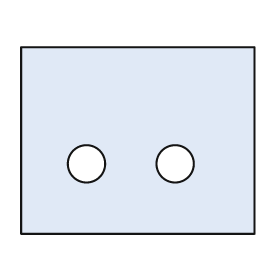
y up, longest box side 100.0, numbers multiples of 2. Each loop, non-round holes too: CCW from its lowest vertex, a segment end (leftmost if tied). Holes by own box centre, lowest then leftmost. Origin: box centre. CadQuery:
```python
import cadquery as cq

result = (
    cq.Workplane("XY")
    .moveTo(-50.0, -40.0)
    .lineTo(50.0, -40.0)
    .lineTo(50.0, 40.0)
    .lineTo(-50.0, 40.0)
    .close()
    .moveTo(-22.0, -10.0)
    .circle(8.0)
    .moveTo(16.0, -10.0)
    .circle(8.0)
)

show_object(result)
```